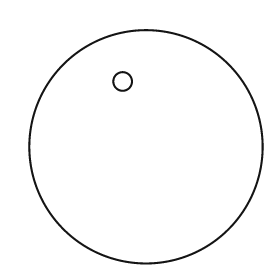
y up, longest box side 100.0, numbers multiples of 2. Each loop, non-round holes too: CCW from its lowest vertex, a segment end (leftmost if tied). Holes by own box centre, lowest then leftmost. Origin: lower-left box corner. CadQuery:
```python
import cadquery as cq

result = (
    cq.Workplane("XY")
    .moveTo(50.0, 50.0)
    .circle(50.0)
    .moveTo(40.0, 78.0)
    .circle(4.0)
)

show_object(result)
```